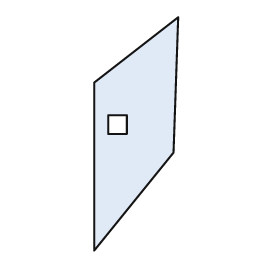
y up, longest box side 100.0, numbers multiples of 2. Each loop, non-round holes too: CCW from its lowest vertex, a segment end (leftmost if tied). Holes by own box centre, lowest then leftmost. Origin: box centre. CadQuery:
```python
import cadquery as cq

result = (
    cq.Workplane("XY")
    .moveTo(-18.0, -50.0)
    .lineTo(16.0, -8.0)
    .lineTo(18.0, 50.0)
    .lineTo(-18.0, 22.0)
    .close()
    .moveTo(-12.0, 0.0)
    .lineTo(-4.0, 0.0)
    .lineTo(-4.0, 8.0)
    .lineTo(-12.0, 8.0)
    .close()
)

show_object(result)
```